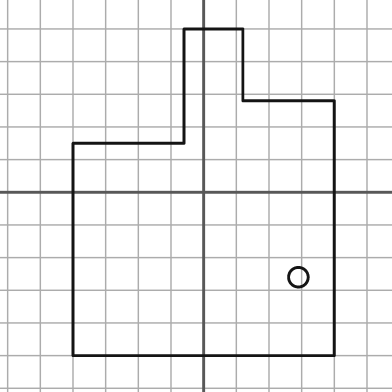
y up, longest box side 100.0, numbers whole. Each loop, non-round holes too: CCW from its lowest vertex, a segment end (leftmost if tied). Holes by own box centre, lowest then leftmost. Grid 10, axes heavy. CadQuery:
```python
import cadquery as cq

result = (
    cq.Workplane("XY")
    .moveTo(-40.0, -50.0)
    .lineTo(40.0, -50.0)
    .lineTo(40.0, 28.0)
    .lineTo(12.0, 28.0)
    .lineTo(12.0, 50.0)
    .lineTo(-6.0, 50.0)
    .lineTo(-6.0, 15.0)
    .lineTo(-40.0, 15.0)
    .close()
    .moveTo(29.0, -26.0)
    .circle(3.0)
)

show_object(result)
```